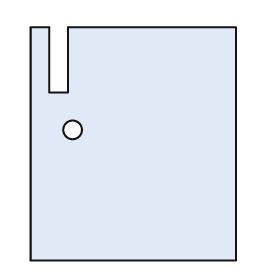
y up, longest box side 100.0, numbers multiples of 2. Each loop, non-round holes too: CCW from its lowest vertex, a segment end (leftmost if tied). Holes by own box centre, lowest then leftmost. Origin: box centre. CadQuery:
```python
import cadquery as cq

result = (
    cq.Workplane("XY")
    .moveTo(-44.0, -50.0)
    .lineTo(44.0, -50.0)
    .lineTo(44.0, 50.0)
    .lineTo(-28.0, 50.0)
    .lineTo(-28.0, 22.0)
    .lineTo(-36.0, 22.0)
    .lineTo(-36.0, 50.0)
    .lineTo(-44.0, 50.0)
    .close()
    .moveTo(-26.0, 6.0)
    .circle(4.0)
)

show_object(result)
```